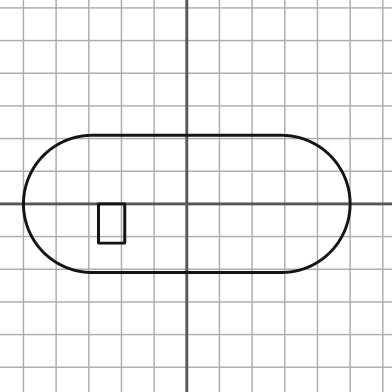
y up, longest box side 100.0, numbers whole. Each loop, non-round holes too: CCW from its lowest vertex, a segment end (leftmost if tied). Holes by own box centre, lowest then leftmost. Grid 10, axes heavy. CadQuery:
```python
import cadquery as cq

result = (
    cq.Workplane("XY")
    .moveTo(-29.0, -21.0)
    .lineTo(29.0, -21.0)
    .threePointArc((50.0, 0.0), (29.0, 21.0))
    .lineTo(-29.0, 21.0)
    .threePointArc((-50.0, 0.0), (-29.0, -21.0))
    .close()
    .moveTo(-27.0, -12.0)
    .lineTo(-19.0, -12.0)
    .lineTo(-19.0, 0.0)
    .lineTo(-27.0, 0.0)
    .close()
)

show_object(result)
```